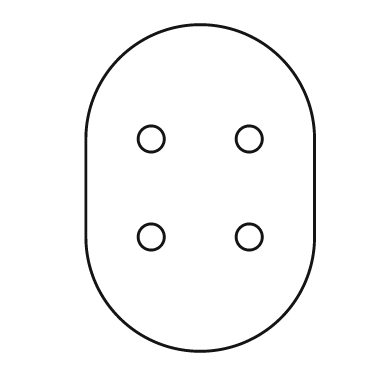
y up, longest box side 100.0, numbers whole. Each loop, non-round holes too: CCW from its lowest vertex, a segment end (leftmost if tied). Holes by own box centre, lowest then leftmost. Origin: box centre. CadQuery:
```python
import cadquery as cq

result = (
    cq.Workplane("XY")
    .moveTo(-35.0, -15.0)
    .threePointArc((0.0, -50.0), (35.0, -15.0))
    .lineTo(35.0, 15.0)
    .threePointArc((0.0, 50.0), (-35.0, 15.0))
    .close()
    .moveTo(-15.0, -15.0)
    .circle(4.0)
    .moveTo(15.0, -15.0)
    .circle(4.0)
    .moveTo(-15.0, 15.0)
    .circle(4.0)
    .moveTo(15.0, 15.0)
    .circle(4.0)
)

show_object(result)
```